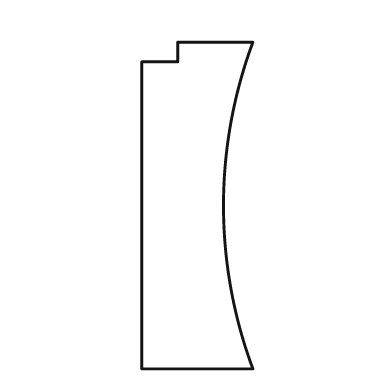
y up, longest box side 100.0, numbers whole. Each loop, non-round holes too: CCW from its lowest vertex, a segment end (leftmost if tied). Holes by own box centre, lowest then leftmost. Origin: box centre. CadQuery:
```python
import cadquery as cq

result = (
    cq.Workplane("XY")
    .moveTo(-17.0, -50.0)
    .lineTo(17.0, -50.0)
    .threePointArc((8.0, 0.0), (17.0, 50.0))
    .lineTo(-6.0, 50.0)
    .lineTo(-6.0, 44.0)
    .lineTo(-17.0, 44.0)
    .close()
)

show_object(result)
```